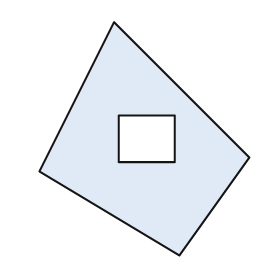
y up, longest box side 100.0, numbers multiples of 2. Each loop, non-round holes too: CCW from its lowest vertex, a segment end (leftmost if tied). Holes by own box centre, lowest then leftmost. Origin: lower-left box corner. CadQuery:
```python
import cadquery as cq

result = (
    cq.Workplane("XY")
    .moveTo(60.0, 0.0)
    .lineTo(90.0, 42.0)
    .lineTo(32.0, 100.0)
    .lineTo(0.0, 36.0)
    .close()
    .moveTo(34.0, 40.0)
    .lineTo(58.0, 40.0)
    .lineTo(58.0, 60.0)
    .lineTo(34.0, 60.0)
    .close()
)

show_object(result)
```